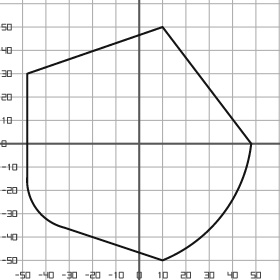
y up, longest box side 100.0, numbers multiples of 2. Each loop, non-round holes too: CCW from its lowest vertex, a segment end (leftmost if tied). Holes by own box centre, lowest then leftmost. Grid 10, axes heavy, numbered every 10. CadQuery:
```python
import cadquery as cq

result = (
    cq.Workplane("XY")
    .moveTo(10.0, -50.0)
    .threePointArc((36.0, -30.0), (48.0, 0.0))
    .lineTo(10.0, 50.0)
    .lineTo(-48.0, 30.0)
    .lineTo(-48.0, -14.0)
    .threePointArc((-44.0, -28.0), (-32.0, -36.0))
    .close()
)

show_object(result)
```